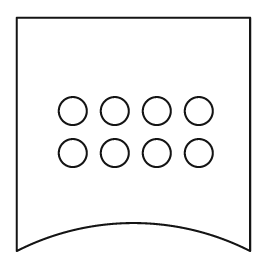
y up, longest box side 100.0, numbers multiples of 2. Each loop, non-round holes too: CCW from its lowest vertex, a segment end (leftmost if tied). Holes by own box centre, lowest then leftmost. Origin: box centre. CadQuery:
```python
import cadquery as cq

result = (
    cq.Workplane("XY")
    .moveTo(-50.0, -50.0)
    .threePointArc((0.0, -38.0), (50.0, -50.0))
    .lineTo(50.0, 50.0)
    .lineTo(-50.0, 50.0)
    .close()
    .moveTo(-26.0, -8.0)
    .circle(6.0)
    .moveTo(-8.0, -8.0)
    .circle(6.0)
    .moveTo(10.0, -8.0)
    .circle(6.0)
    .moveTo(28.0, -8.0)
    .circle(6.0)
    .moveTo(-26.0, 10.0)
    .circle(6.0)
    .moveTo(-8.0, 10.0)
    .circle(6.0)
    .moveTo(10.0, 10.0)
    .circle(6.0)
    .moveTo(28.0, 10.0)
    .circle(6.0)
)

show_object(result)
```